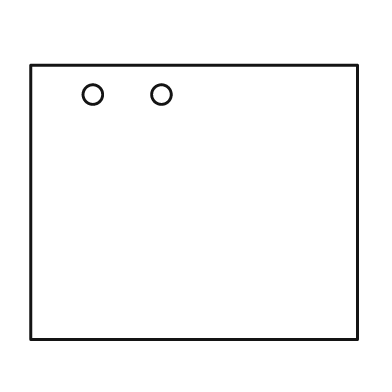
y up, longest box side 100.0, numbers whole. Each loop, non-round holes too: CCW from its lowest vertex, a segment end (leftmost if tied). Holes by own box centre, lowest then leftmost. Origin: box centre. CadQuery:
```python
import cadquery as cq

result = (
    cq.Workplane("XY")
    .moveTo(-50.0, -42.0)
    .lineTo(50.0, -42.0)
    .lineTo(50.0, 42.0)
    .lineTo(-50.0, 42.0)
    .close()
    .moveTo(-31.0, 33.0)
    .circle(3.0)
    .moveTo(-10.0, 33.0)
    .circle(3.0)
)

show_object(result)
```